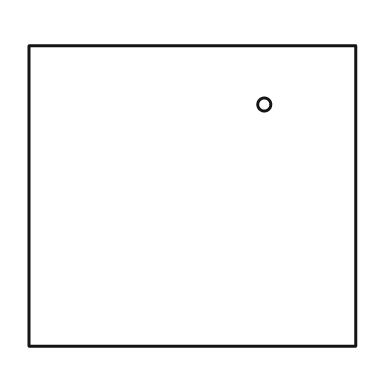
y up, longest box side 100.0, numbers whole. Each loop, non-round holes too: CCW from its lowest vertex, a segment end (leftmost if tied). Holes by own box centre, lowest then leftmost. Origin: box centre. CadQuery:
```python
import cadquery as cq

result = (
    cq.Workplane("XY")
    .moveTo(-50.0, -46.0)
    .lineTo(50.0, -46.0)
    .lineTo(50.0, 46.0)
    .lineTo(-50.0, 46.0)
    .close()
    .moveTo(22.0, 28.0)
    .circle(2.0)
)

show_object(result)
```